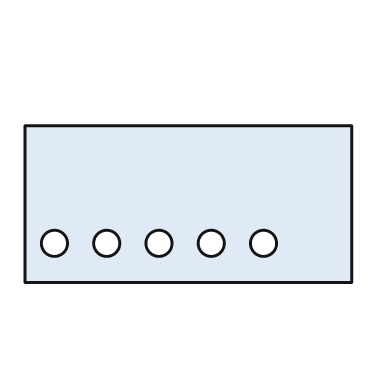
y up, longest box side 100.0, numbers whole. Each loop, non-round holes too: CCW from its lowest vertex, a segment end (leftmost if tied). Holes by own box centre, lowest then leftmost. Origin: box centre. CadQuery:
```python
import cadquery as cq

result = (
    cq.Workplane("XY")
    .moveTo(-50.0, -24.0)
    .lineTo(50.0, -24.0)
    .lineTo(50.0, 24.0)
    .lineTo(-50.0, 24.0)
    .close()
    .moveTo(-41.0, -12.0)
    .circle(4.0)
    .moveTo(-25.0, -12.0)
    .circle(4.0)
    .moveTo(-9.0, -12.0)
    .circle(4.0)
    .moveTo(7.0, -12.0)
    .circle(4.0)
    .moveTo(23.0, -12.0)
    .circle(4.0)
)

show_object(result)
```